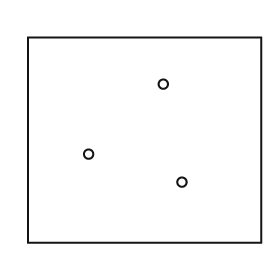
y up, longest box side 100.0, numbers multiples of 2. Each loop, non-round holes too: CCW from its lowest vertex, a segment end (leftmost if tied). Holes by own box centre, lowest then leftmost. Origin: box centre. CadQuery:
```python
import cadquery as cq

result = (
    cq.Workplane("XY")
    .moveTo(-50.0, -44.0)
    .lineTo(50.0, -44.0)
    .lineTo(50.0, 44.0)
    .lineTo(-50.0, 44.0)
    .close()
    .moveTo(16.0, -18.0)
    .circle(2.0)
    .moveTo(-24.0, -6.0)
    .circle(2.0)
    .moveTo(8.0, 24.0)
    .circle(2.0)
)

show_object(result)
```